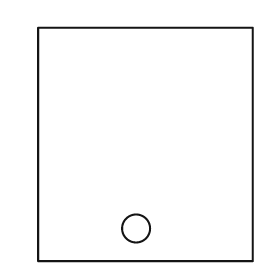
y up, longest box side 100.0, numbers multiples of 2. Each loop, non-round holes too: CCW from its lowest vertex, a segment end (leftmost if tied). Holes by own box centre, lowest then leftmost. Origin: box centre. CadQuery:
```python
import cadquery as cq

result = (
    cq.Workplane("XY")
    .moveTo(-46.0, -50.0)
    .lineTo(46.0, -50.0)
    .lineTo(46.0, 50.0)
    .lineTo(-46.0, 50.0)
    .close()
    .moveTo(-4.0, -36.0)
    .circle(6.0)
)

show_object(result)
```